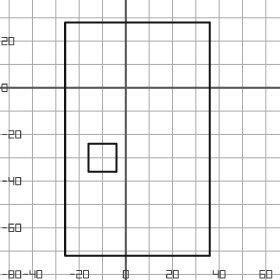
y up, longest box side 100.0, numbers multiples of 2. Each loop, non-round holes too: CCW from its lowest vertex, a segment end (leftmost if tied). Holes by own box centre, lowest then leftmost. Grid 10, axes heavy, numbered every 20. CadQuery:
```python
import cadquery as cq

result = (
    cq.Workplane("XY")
    .moveTo(-26.0, -72.0)
    .lineTo(36.0, -72.0)
    .lineTo(36.0, 28.0)
    .lineTo(-26.0, 28.0)
    .close()
    .moveTo(-16.0, -36.0)
    .lineTo(-4.0, -36.0)
    .lineTo(-4.0, -24.0)
    .lineTo(-16.0, -24.0)
    .close()
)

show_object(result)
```